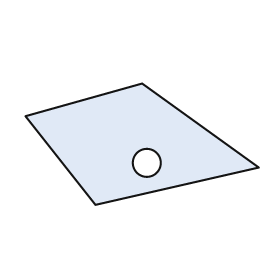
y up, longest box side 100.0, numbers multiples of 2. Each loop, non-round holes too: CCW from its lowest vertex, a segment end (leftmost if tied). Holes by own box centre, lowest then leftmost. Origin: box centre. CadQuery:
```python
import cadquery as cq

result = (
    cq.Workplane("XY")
    .moveTo(-20.0, -26.0)
    .lineTo(50.0, -10.0)
    .lineTo(0.0, 26.0)
    .lineTo(-50.0, 12.0)
    .close()
    .moveTo(2.0, -8.0)
    .circle(6.0)
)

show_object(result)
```